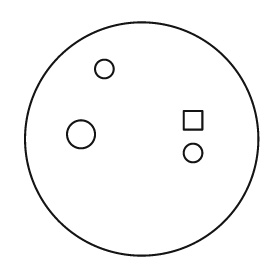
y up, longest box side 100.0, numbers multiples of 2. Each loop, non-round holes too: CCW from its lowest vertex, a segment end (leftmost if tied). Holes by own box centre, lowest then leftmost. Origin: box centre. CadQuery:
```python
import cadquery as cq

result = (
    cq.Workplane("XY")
    .moveTo(0.0, 0.0)
    .circle(50.0)
    .moveTo(22.0, -6.0)
    .circle(4.0)
    .moveTo(-26.0, 2.0)
    .circle(6.0)
    .moveTo(18.0, 4.0)
    .lineTo(26.0, 4.0)
    .lineTo(26.0, 12.0)
    .lineTo(18.0, 12.0)
    .close()
    .moveTo(-16.0, 30.0)
    .circle(4.0)
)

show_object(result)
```